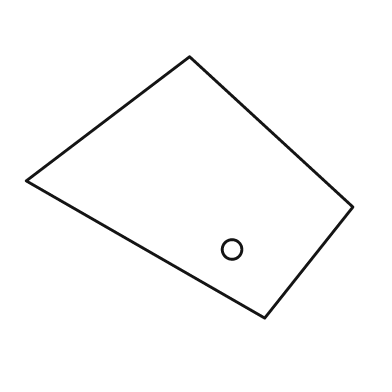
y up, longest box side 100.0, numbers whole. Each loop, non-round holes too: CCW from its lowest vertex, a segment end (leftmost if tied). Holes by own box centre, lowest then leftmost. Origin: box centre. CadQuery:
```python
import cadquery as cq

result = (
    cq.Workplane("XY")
    .moveTo(23.0, -40.0)
    .lineTo(50.0, -6.0)
    .lineTo(0.0, 40.0)
    .lineTo(-50.0, 2.0)
    .close()
    .moveTo(13.0, -19.0)
    .circle(3.0)
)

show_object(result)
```